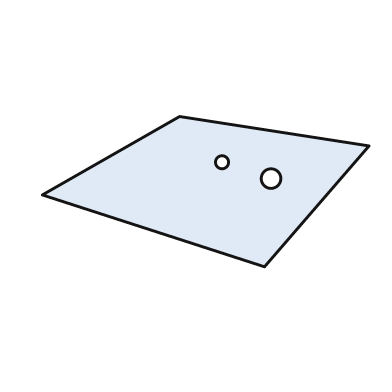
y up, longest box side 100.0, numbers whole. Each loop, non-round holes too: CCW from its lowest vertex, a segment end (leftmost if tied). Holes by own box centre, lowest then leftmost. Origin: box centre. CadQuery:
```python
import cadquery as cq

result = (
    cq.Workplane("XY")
    .moveTo(18.0, -23.0)
    .lineTo(50.0, 14.0)
    .lineTo(-8.0, 23.0)
    .lineTo(-50.0, -1.0)
    .close()
    .moveTo(20.0, 4.0)
    .circle(3.0)
    .moveTo(5.0, 9.0)
    .circle(2.0)
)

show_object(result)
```